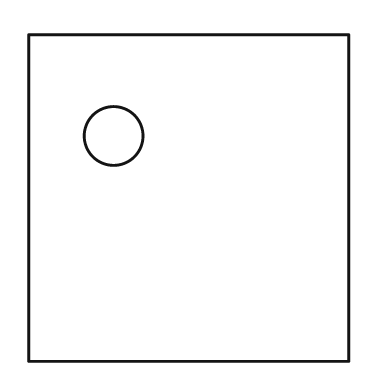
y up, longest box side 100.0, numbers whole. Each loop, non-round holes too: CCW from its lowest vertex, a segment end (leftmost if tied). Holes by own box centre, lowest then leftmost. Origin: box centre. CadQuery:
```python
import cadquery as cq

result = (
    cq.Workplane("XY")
    .moveTo(-49.0, -50.0)
    .lineTo(49.0, -50.0)
    .lineTo(49.0, 50.0)
    .lineTo(-49.0, 50.0)
    .close()
    .moveTo(-23.0, 19.0)
    .circle(9.0)
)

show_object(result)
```